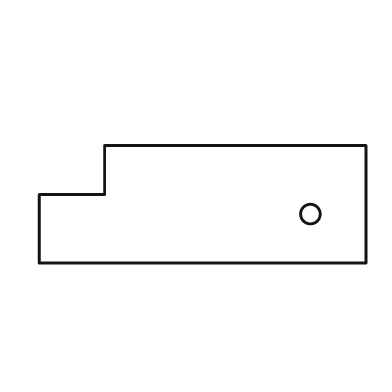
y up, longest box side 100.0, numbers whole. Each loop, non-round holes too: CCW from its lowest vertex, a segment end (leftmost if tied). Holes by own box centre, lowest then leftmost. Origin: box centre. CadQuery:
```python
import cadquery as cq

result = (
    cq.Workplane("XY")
    .moveTo(-50.0, -18.0)
    .lineTo(50.0, -18.0)
    .lineTo(50.0, 18.0)
    .lineTo(-30.0, 18.0)
    .lineTo(-30.0, 3.0)
    .lineTo(-50.0, 3.0)
    .close()
    .moveTo(33.0, -3.0)
    .circle(3.0)
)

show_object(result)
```